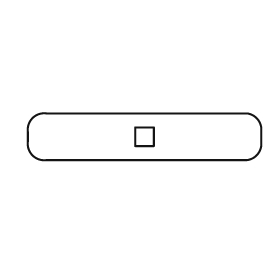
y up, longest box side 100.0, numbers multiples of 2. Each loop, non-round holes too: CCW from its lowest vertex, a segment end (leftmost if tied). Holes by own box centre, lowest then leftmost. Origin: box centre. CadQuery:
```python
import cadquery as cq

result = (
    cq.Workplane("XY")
    .moveTo(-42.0, -10.0)
    .lineTo(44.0, -10.0)
    .threePointArc((48.0, -8.0), (50.0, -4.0))
    .lineTo(50.0, 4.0)
    .threePointArc((48.0, 8.0), (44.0, 10.0))
    .lineTo(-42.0, 10.0)
    .threePointArc((-48.0, 8.0), (-50.0, 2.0))
    .lineTo(-50.0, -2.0)
    .threePointArc((-48.0, -8.0), (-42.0, -10.0))
    .close()
    .moveTo(-4.0, -4.0)
    .lineTo(4.0, -4.0)
    .lineTo(4.0, 4.0)
    .lineTo(-4.0, 4.0)
    .close()
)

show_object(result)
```